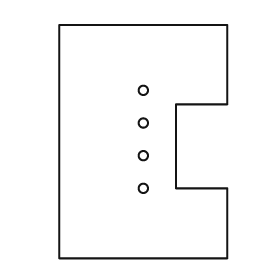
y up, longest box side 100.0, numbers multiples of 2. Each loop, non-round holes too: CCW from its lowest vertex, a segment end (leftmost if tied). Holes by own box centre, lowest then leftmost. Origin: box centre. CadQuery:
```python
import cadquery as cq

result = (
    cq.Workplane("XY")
    .moveTo(-36.0, -50.0)
    .lineTo(36.0, -50.0)
    .lineTo(36.0, -20.0)
    .lineTo(14.0, -20.0)
    .lineTo(14.0, 16.0)
    .lineTo(36.0, 16.0)
    .lineTo(36.0, 50.0)
    .lineTo(-36.0, 50.0)
    .close()
    .moveTo(0.0, -20.0)
    .circle(2.0)
    .moveTo(0.0, -6.0)
    .circle(2.0)
    .moveTo(0.0, 8.0)
    .circle(2.0)
    .moveTo(0.0, 22.0)
    .circle(2.0)
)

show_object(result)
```